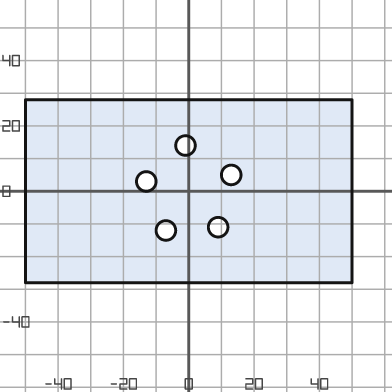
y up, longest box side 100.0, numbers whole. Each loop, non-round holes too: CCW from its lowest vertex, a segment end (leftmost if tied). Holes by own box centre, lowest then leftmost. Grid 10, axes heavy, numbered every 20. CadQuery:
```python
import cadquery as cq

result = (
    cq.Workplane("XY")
    .moveTo(-50.0, -28.0)
    .lineTo(50.0, -28.0)
    .lineTo(50.0, 28.0)
    .lineTo(-50.0, 28.0)
    .close()
    .moveTo(-7.0, -12.0)
    .circle(3.0)
    .moveTo(9.0, -11.0)
    .circle(3.0)
    .moveTo(-13.0, 3.0)
    .circle(3.0)
    .moveTo(13.0, 5.0)
    .circle(3.0)
    .moveTo(-1.0, 14.0)
    .circle(3.0)
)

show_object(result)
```